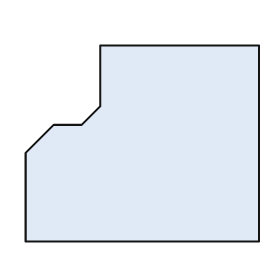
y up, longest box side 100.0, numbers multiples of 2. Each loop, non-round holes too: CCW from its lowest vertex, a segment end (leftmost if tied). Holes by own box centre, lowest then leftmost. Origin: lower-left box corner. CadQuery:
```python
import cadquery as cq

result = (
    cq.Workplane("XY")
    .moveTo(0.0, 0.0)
    .lineTo(100.0, 0.0)
    .lineTo(100.0, 84.0)
    .lineTo(32.0, 84.0)
    .lineTo(32.0, 58.0)
    .lineTo(24.0, 50.0)
    .lineTo(12.0, 50.0)
    .lineTo(0.0, 38.0)
    .close()
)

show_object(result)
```